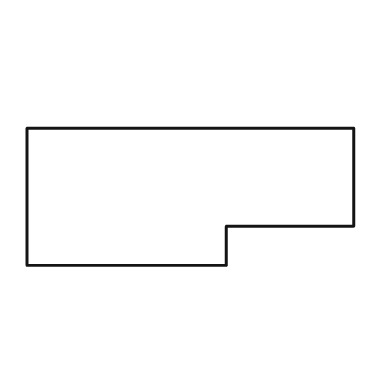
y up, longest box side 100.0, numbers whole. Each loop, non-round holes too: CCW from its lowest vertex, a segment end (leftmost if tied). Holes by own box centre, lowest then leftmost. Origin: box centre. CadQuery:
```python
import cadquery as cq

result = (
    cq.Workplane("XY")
    .moveTo(-50.0, -21.0)
    .lineTo(11.0, -21.0)
    .lineTo(11.0, -9.0)
    .lineTo(50.0, -9.0)
    .lineTo(50.0, 21.0)
    .lineTo(-50.0, 21.0)
    .close()
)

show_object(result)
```